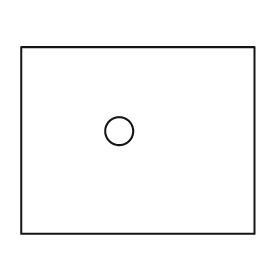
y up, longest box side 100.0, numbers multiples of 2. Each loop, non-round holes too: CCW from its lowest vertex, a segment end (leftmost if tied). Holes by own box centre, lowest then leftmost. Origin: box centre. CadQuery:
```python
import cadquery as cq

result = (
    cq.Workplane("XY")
    .moveTo(-50.0, -40.0)
    .lineTo(50.0, -40.0)
    .lineTo(50.0, 40.0)
    .lineTo(-50.0, 40.0)
    .close()
    .moveTo(-8.0, 4.0)
    .circle(6.0)
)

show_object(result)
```